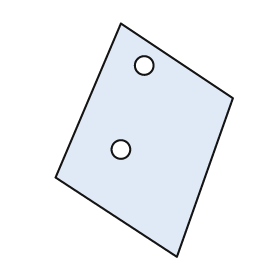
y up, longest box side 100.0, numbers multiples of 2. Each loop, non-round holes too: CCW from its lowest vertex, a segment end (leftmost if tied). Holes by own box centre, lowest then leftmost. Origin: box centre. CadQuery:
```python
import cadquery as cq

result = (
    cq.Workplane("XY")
    .moveTo(14.0, -50.0)
    .lineTo(38.0, 18.0)
    .lineTo(-10.0, 50.0)
    .lineTo(-38.0, -16.0)
    .close()
    .moveTo(-10.0, -4.0)
    .circle(4.0)
    .moveTo(0.0, 32.0)
    .circle(4.0)
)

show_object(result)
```